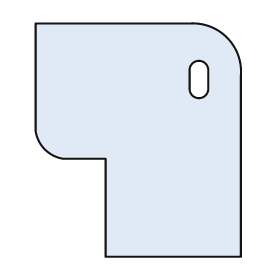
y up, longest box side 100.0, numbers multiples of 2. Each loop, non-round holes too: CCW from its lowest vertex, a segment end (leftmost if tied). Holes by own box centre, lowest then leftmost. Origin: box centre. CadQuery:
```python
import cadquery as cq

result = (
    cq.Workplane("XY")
    .moveTo(-14.0, -50.0)
    .lineTo(44.0, -50.0)
    .lineTo(44.0, 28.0)
    .threePointArc((38.0, 44.0), (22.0, 50.0))
    .lineTo(-44.0, 50.0)
    .lineTo(-44.0, 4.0)
    .threePointArc((-40.0, -4.0), (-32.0, -8.0))
    .lineTo(-14.0, -8.0)
    .close()
    .moveTo(22.0, 22.0)
    .threePointArc((26.0, 18.0), (30.0, 22.0))
    .lineTo(30.0, 30.0)
    .threePointArc((26.0, 34.0), (22.0, 30.0))
    .close()
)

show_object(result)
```